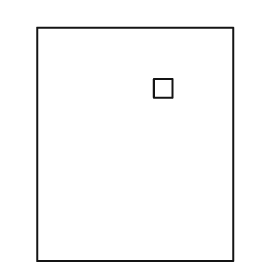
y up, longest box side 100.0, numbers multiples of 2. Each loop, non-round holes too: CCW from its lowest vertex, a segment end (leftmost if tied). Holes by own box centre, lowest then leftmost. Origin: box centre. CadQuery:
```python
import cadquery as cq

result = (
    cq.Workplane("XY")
    .moveTo(-42.0, -50.0)
    .lineTo(42.0, -50.0)
    .lineTo(42.0, 50.0)
    .lineTo(-42.0, 50.0)
    .close()
    .moveTo(8.0, 20.0)
    .lineTo(16.0, 20.0)
    .lineTo(16.0, 28.0)
    .lineTo(8.0, 28.0)
    .close()
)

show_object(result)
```